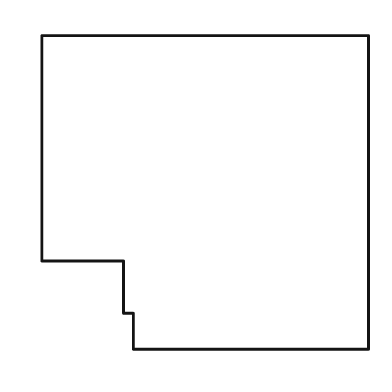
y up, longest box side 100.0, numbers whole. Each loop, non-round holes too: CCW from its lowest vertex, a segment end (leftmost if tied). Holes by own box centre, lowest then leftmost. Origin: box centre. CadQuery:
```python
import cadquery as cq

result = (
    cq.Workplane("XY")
    .moveTo(-22.0, -48.0)
    .lineTo(50.0, -48.0)
    .lineTo(50.0, 48.0)
    .lineTo(-50.0, 48.0)
    .lineTo(-50.0, -21.0)
    .lineTo(-25.0, -21.0)
    .lineTo(-25.0, -37.0)
    .lineTo(-22.0, -37.0)
    .close()
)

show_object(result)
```